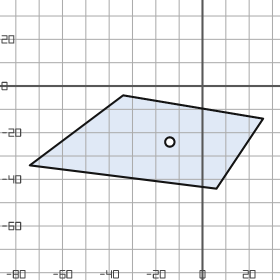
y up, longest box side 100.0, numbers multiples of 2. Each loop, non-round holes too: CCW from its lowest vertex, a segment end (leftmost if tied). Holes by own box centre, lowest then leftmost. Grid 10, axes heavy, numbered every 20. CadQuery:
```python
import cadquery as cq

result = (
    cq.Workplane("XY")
    .moveTo(6.0, -44.0)
    .lineTo(26.0, -14.0)
    .lineTo(-34.0, -4.0)
    .lineTo(-74.0, -34.0)
    .close()
    .moveTo(-14.0, -24.0)
    .circle(2.0)
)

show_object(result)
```